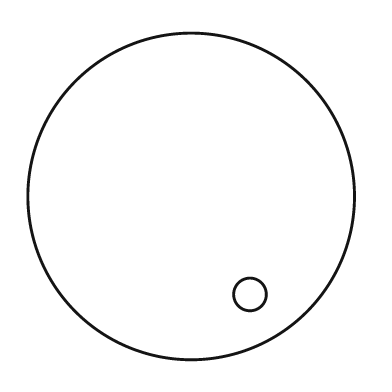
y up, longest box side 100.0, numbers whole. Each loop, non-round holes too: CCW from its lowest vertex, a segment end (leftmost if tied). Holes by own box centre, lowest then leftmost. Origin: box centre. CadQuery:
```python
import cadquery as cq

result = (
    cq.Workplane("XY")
    .moveTo(0.0, 0.0)
    .circle(50.0)
    .moveTo(18.0, -30.0)
    .circle(5.0)
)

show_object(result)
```